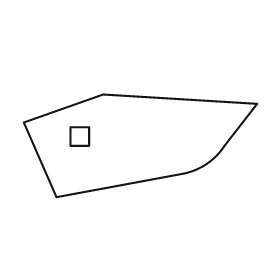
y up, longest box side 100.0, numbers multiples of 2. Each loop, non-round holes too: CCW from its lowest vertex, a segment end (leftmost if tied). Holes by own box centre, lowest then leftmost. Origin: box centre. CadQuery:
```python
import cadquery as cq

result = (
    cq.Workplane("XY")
    .moveTo(-36.0, -22.0)
    .lineTo(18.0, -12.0)
    .threePointArc((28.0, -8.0), (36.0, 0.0))
    .lineTo(50.0, 18.0)
    .lineTo(-16.0, 22.0)
    .lineTo(-50.0, 10.0)
    .close()
    .moveTo(-30.0, 0.0)
    .lineTo(-22.0, 0.0)
    .lineTo(-22.0, 8.0)
    .lineTo(-30.0, 8.0)
    .close()
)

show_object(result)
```